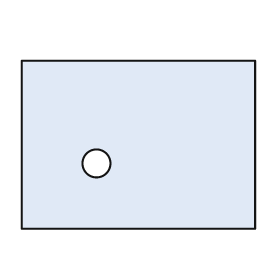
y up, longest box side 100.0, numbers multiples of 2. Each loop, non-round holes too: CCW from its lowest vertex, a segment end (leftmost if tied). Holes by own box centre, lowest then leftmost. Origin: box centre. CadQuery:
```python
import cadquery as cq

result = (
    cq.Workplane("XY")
    .moveTo(-50.0, -36.0)
    .lineTo(50.0, -36.0)
    .lineTo(50.0, 36.0)
    .lineTo(-50.0, 36.0)
    .close()
    .moveTo(-18.0, -8.0)
    .circle(6.0)
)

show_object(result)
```